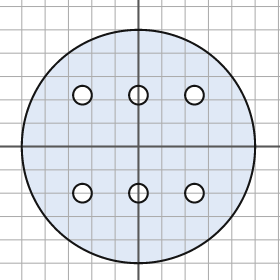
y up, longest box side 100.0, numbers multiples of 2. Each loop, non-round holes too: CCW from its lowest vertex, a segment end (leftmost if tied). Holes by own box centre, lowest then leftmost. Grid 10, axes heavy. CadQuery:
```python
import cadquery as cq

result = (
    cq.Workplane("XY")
    .moveTo(0.0, 0.0)
    .circle(50.0)
    .moveTo(-24.0, -20.0)
    .circle(4.0)
    .moveTo(0.0, -20.0)
    .circle(4.0)
    .moveTo(24.0, -20.0)
    .circle(4.0)
    .moveTo(-24.0, 22.0)
    .circle(4.0)
    .moveTo(0.0, 22.0)
    .circle(4.0)
    .moveTo(24.0, 22.0)
    .circle(4.0)
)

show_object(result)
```